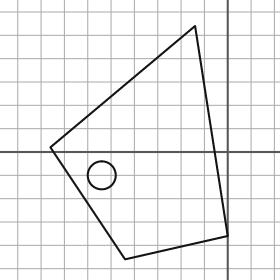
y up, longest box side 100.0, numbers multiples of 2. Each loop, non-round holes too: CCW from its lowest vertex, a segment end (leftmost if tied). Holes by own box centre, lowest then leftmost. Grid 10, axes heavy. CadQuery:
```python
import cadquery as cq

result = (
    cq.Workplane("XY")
    .moveTo(-44.0, -46.0)
    .lineTo(0.0, -36.0)
    .lineTo(-14.0, 54.0)
    .lineTo(-76.0, 2.0)
    .close()
    .moveTo(-54.0, -10.0)
    .circle(6.0)
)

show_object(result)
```